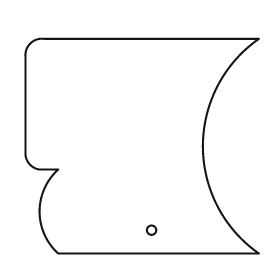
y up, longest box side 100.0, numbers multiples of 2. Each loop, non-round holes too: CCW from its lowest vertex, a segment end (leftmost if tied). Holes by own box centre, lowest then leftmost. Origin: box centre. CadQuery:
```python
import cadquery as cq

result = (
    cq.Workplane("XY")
    .moveTo(-36.0, -46.0)
    .lineTo(50.0, -46.0)
    .threePointArc((26.0, 0.0), (50.0, 46.0))
    .lineTo(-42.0, 46.0)
    .threePointArc((-48.0, 44.0), (-50.0, 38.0))
    .lineTo(-50.0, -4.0)
    .threePointArc((-48.0, -8.0), (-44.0, -10.0))
    .lineTo(-36.0, -10.0)
    .threePointArc((-44.0, -28.0), (-36.0, -46.0))
    .close()
    .moveTo(4.0, -36.0)
    .circle(2.0)
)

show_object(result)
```